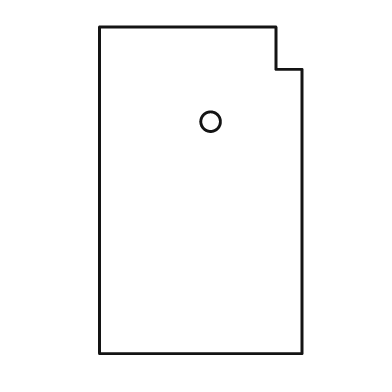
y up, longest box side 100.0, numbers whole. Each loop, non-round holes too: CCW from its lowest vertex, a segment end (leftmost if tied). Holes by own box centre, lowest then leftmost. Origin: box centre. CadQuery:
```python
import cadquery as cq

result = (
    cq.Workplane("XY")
    .moveTo(-31.0, -50.0)
    .lineTo(31.0, -50.0)
    .lineTo(31.0, 37.0)
    .lineTo(23.0, 37.0)
    .lineTo(23.0, 50.0)
    .lineTo(-31.0, 50.0)
    .close()
    .moveTo(3.0, 21.0)
    .circle(3.0)
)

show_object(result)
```